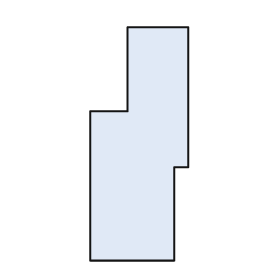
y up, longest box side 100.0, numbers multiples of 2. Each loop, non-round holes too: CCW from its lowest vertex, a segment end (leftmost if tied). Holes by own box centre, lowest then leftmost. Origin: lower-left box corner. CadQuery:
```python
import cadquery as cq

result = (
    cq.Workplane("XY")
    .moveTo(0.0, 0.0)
    .lineTo(36.0, 0.0)
    .lineTo(36.0, 40.0)
    .lineTo(42.0, 40.0)
    .lineTo(42.0, 100.0)
    .lineTo(16.0, 100.0)
    .lineTo(16.0, 64.0)
    .lineTo(0.0, 64.0)
    .close()
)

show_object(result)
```